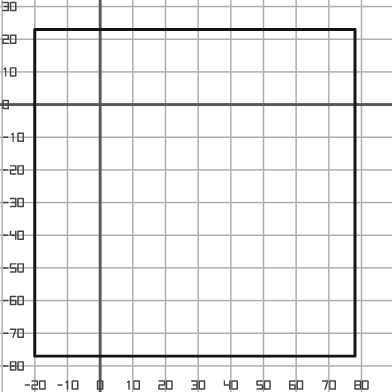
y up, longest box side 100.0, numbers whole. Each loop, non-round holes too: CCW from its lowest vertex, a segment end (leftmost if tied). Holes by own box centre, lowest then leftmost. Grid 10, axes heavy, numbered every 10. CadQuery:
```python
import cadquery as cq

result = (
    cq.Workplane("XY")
    .moveTo(-20.0, -77.0)
    .lineTo(78.0, -77.0)
    .lineTo(78.0, 23.0)
    .lineTo(-20.0, 23.0)
    .close()
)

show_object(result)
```